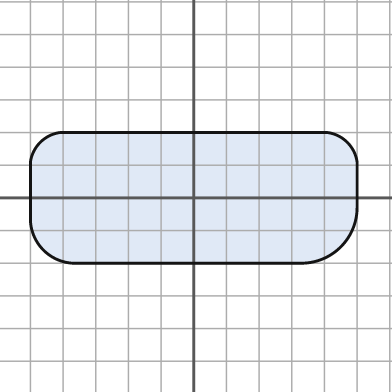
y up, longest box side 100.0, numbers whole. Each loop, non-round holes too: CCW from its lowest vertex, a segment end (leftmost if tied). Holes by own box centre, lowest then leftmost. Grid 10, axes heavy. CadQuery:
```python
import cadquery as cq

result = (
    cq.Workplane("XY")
    .moveTo(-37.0, -20.0)
    .lineTo(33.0, -20.0)
    .threePointArc((45.0, -15.0), (50.0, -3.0))
    .lineTo(50.0, 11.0)
    .threePointArc((47.0, 17.0), (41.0, 20.0))
    .lineTo(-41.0, 20.0)
    .threePointArc((-47.0, 17.0), (-50.0, 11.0))
    .lineTo(-50.0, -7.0)
    .threePointArc((-46.0, -16.0), (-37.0, -20.0))
    .close()
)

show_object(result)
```